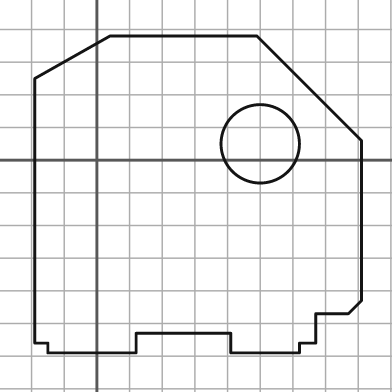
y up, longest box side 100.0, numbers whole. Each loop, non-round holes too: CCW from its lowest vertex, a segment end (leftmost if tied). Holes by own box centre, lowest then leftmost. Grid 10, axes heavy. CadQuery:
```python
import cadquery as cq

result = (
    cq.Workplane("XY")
    .moveTo(-15.0, -59.0)
    .lineTo(12.0, -59.0)
    .lineTo(12.0, -53.0)
    .lineTo(41.0, -53.0)
    .lineTo(41.0, -59.0)
    .lineTo(62.0, -59.0)
    .lineTo(62.0, -56.0)
    .lineTo(67.0, -56.0)
    .lineTo(67.0, -47.0)
    .lineTo(77.0, -47.0)
    .lineTo(81.0, -43.0)
    .lineTo(81.0, 6.0)
    .lineTo(49.0, 38.0)
    .lineTo(4.0, 38.0)
    .lineTo(-19.0, 25.0)
    .lineTo(-19.0, -56.0)
    .lineTo(-15.0, -56.0)
    .close()
    .moveTo(50.0, 5.0)
    .circle(12.0)
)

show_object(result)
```